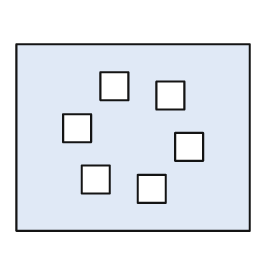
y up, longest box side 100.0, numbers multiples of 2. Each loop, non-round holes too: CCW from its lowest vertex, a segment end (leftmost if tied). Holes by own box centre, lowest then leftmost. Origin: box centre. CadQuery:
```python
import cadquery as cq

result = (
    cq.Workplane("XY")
    .moveTo(-50.0, -40.0)
    .lineTo(50.0, -40.0)
    .lineTo(50.0, 40.0)
    .lineTo(-50.0, 40.0)
    .close()
    .moveTo(2.0, -28.0)
    .lineTo(14.0, -28.0)
    .lineTo(14.0, -16.0)
    .lineTo(2.0, -16.0)
    .close()
    .moveTo(-22.0, -24.0)
    .lineTo(-10.0, -24.0)
    .lineTo(-10.0, -12.0)
    .lineTo(-22.0, -12.0)
    .close()
    .moveTo(18.0, -10.0)
    .lineTo(30.0, -10.0)
    .lineTo(30.0, 2.0)
    .lineTo(18.0, 2.0)
    .close()
    .moveTo(-30.0, -2.0)
    .lineTo(-18.0, -2.0)
    .lineTo(-18.0, 10.0)
    .lineTo(-30.0, 10.0)
    .close()
    .moveTo(10.0, 12.0)
    .lineTo(22.0, 12.0)
    .lineTo(22.0, 24.0)
    .lineTo(10.0, 24.0)
    .close()
    .moveTo(-14.0, 16.0)
    .lineTo(-2.0, 16.0)
    .lineTo(-2.0, 28.0)
    .lineTo(-14.0, 28.0)
    .close()
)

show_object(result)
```